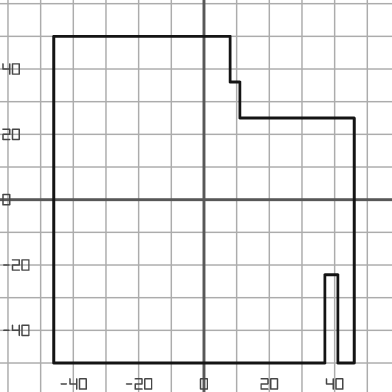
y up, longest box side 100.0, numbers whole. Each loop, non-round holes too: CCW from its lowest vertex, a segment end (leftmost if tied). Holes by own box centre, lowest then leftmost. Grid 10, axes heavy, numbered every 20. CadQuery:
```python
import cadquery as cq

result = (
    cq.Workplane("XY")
    .moveTo(-46.0, -50.0)
    .lineTo(37.0, -50.0)
    .lineTo(37.0, -23.0)
    .lineTo(41.0, -23.0)
    .lineTo(41.0, -50.0)
    .lineTo(46.0, -50.0)
    .lineTo(46.0, 25.0)
    .lineTo(11.0, 25.0)
    .lineTo(11.0, 36.0)
    .lineTo(8.0, 36.0)
    .lineTo(8.0, 50.0)
    .lineTo(-46.0, 50.0)
    .close()
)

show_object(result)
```